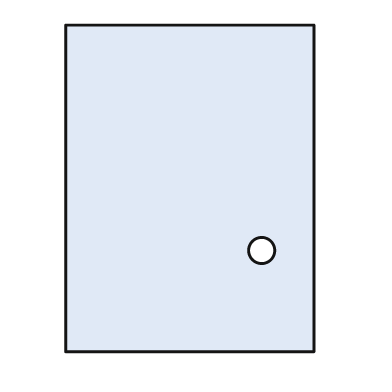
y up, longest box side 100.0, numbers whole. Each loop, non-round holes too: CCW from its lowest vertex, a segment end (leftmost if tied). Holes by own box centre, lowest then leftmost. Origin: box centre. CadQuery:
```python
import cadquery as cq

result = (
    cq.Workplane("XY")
    .moveTo(-38.0, -50.0)
    .lineTo(38.0, -50.0)
    .lineTo(38.0, 50.0)
    .lineTo(-38.0, 50.0)
    .close()
    .moveTo(22.0, -19.0)
    .circle(4.0)
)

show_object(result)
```